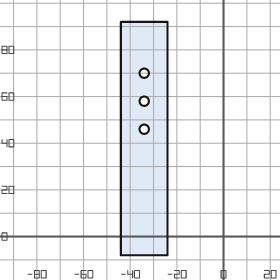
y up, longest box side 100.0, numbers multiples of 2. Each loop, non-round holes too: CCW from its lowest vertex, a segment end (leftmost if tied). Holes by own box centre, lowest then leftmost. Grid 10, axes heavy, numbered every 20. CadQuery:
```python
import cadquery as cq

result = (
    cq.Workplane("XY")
    .moveTo(-44.0, -8.0)
    .lineTo(-24.0, -8.0)
    .lineTo(-24.0, 92.0)
    .lineTo(-44.0, 92.0)
    .close()
    .moveTo(-34.0, 46.0)
    .circle(2.0)
    .moveTo(-34.0, 58.0)
    .circle(2.0)
    .moveTo(-34.0, 70.0)
    .circle(2.0)
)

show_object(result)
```